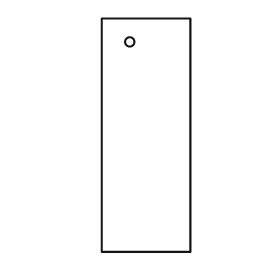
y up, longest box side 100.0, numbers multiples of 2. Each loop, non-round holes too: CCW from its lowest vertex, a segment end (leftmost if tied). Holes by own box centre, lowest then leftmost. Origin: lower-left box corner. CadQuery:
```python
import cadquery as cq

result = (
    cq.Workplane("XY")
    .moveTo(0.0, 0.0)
    .lineTo(38.0, 0.0)
    .lineTo(38.0, 100.0)
    .lineTo(0.0, 100.0)
    .close()
    .moveTo(12.0, 90.0)
    .circle(2.0)
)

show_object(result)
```